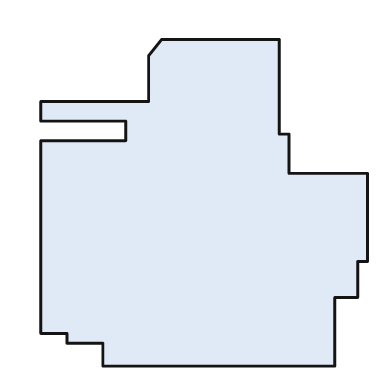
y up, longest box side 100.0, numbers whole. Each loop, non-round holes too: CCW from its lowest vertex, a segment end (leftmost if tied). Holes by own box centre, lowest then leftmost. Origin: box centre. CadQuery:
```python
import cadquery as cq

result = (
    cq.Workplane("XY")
    .moveTo(-31.0, -50.0)
    .lineTo(40.0, -50.0)
    .lineTo(40.0, -29.0)
    .lineTo(47.0, -29.0)
    .lineTo(47.0, -18.0)
    .lineTo(50.0, -18.0)
    .lineTo(50.0, 9.0)
    .lineTo(26.0, 9.0)
    .lineTo(26.0, 21.0)
    .lineTo(23.0, 21.0)
    .lineTo(23.0, 50.0)
    .lineTo(-13.0, 50.0)
    .lineTo(-17.0, 45.0)
    .lineTo(-17.0, 31.0)
    .lineTo(-50.0, 31.0)
    .lineTo(-50.0, 25.0)
    .lineTo(-24.0, 25.0)
    .lineTo(-24.0, 19.0)
    .lineTo(-50.0, 19.0)
    .lineTo(-50.0, -40.0)
    .lineTo(-42.0, -40.0)
    .lineTo(-42.0, -43.0)
    .lineTo(-31.0, -43.0)
    .close()
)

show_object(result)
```